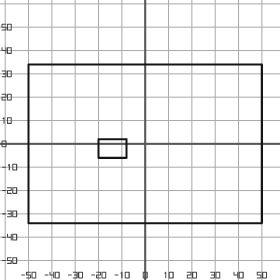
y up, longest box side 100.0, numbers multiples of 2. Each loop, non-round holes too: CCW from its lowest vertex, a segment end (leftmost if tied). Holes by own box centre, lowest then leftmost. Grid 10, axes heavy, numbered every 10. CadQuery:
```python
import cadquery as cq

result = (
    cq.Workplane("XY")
    .moveTo(-50.0, -34.0)
    .lineTo(50.0, -34.0)
    .lineTo(50.0, 34.0)
    .lineTo(-50.0, 34.0)
    .close()
    .moveTo(-20.0, -6.0)
    .lineTo(-8.0, -6.0)
    .lineTo(-8.0, 2.0)
    .lineTo(-20.0, 2.0)
    .close()
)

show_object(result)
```